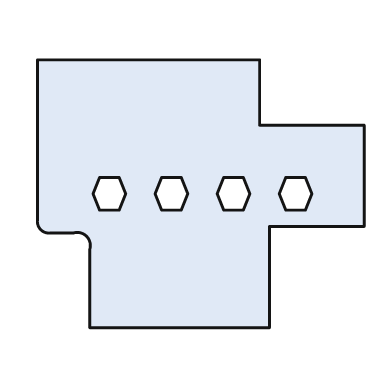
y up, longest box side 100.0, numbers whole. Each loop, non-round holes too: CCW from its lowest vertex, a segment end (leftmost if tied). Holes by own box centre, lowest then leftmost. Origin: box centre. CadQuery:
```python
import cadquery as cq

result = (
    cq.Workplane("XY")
    .moveTo(-34.0, -41.0)
    .lineTo(21.0, -41.0)
    .lineTo(21.0, -10.0)
    .lineTo(50.0, -10.0)
    .lineTo(50.0, 21.0)
    .lineTo(18.0, 21.0)
    .lineTo(18.0, 41.0)
    .lineTo(-50.0, 41.0)
    .lineTo(-50.0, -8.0)
    .threePointArc((-49.0, -11.0), (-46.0, -12.0))
    .lineTo(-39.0, -12.0)
    .threePointArc((-35.0, -13.0), (-34.0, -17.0))
    .close()
    .moveTo(-31.0, -5.0)
    .lineTo(-25.0, -5.0)
    .lineTo(-23.0, 0.0)
    .lineTo(-25.0, 5.0)
    .lineTo(-31.0, 5.0)
    .lineTo(-33.0, 0.0)
    .close()
    .moveTo(-12.0, -5.0)
    .lineTo(-6.0, -5.0)
    .lineTo(-4.0, 0.0)
    .lineTo(-6.0, 5.0)
    .lineTo(-12.0, 5.0)
    .lineTo(-14.0, 0.0)
    .close()
    .moveTo(7.0, -5.0)
    .lineTo(13.0, -5.0)
    .lineTo(15.0, 0.0)
    .lineTo(13.0, 5.0)
    .lineTo(7.0, 5.0)
    .lineTo(5.0, 0.0)
    .close()
    .moveTo(26.0, -5.0)
    .lineTo(32.0, -5.0)
    .lineTo(34.0, 0.0)
    .lineTo(32.0, 5.0)
    .lineTo(26.0, 5.0)
    .lineTo(24.0, 0.0)
    .close()
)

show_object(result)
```